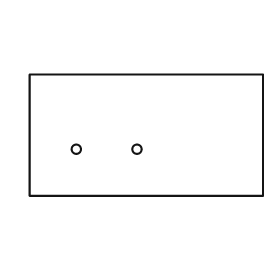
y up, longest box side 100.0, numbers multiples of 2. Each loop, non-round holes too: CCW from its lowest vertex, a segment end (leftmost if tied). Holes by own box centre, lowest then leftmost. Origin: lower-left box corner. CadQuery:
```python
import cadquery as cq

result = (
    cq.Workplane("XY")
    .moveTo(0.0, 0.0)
    .lineTo(100.0, 0.0)
    .lineTo(100.0, 52.0)
    .lineTo(0.0, 52.0)
    .close()
    .moveTo(20.0, 20.0)
    .circle(2.0)
    .moveTo(46.0, 20.0)
    .circle(2.0)
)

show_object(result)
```